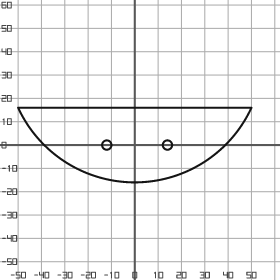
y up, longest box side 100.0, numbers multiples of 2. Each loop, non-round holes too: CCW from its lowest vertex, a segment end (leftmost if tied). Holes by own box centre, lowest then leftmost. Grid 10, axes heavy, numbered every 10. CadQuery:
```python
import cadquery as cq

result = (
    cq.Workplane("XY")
    .moveTo(-50.0, 16.0)
    .threePointArc((0.0, -16.0), (50.0, 16.0))
    .close()
    .moveTo(-12.0, 0.0)
    .circle(2.0)
    .moveTo(14.0, 0.0)
    .circle(2.0)
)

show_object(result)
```